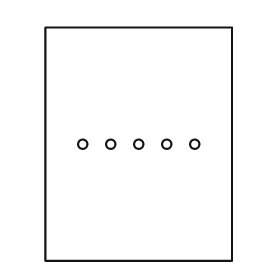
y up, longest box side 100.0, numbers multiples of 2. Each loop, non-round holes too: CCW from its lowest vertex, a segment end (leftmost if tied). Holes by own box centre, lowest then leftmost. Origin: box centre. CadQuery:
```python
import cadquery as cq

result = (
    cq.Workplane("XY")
    .moveTo(-40.0, -50.0)
    .lineTo(40.0, -50.0)
    .lineTo(40.0, 50.0)
    .lineTo(-40.0, 50.0)
    .close()
    .moveTo(-24.0, 0.0)
    .circle(2.0)
    .moveTo(-12.0, 0.0)
    .circle(2.0)
    .moveTo(0.0, 0.0)
    .circle(2.0)
    .moveTo(12.0, 0.0)
    .circle(2.0)
    .moveTo(24.0, 0.0)
    .circle(2.0)
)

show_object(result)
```